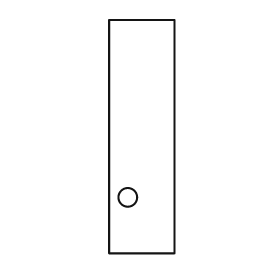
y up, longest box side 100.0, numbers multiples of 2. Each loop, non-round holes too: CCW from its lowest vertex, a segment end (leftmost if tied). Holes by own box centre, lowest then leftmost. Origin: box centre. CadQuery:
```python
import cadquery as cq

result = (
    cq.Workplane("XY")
    .moveTo(-14.0, -50.0)
    .lineTo(14.0, -50.0)
    .lineTo(14.0, 50.0)
    .lineTo(-14.0, 50.0)
    .close()
    .moveTo(-6.0, -26.0)
    .circle(4.0)
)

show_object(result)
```